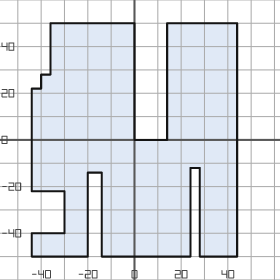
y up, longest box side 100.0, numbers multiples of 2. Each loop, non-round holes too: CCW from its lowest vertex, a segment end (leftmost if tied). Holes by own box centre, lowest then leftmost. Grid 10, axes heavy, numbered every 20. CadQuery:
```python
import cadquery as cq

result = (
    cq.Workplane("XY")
    .moveTo(-44.0, -50.0)
    .lineTo(-20.0, -50.0)
    .lineTo(-20.0, -14.0)
    .lineTo(-14.0, -14.0)
    .lineTo(-14.0, -50.0)
    .lineTo(24.0, -50.0)
    .lineTo(24.0, -12.0)
    .lineTo(28.0, -12.0)
    .lineTo(28.0, -50.0)
    .lineTo(44.0, -50.0)
    .lineTo(44.0, 50.0)
    .lineTo(14.0, 50.0)
    .lineTo(14.0, 0.0)
    .lineTo(0.0, 0.0)
    .lineTo(0.0, 50.0)
    .lineTo(-36.0, 50.0)
    .lineTo(-36.0, 28.0)
    .lineTo(-40.0, 28.0)
    .lineTo(-40.0, 22.0)
    .lineTo(-44.0, 22.0)
    .lineTo(-44.0, -22.0)
    .lineTo(-30.0, -22.0)
    .lineTo(-30.0, -40.0)
    .lineTo(-44.0, -40.0)
    .close()
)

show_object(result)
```